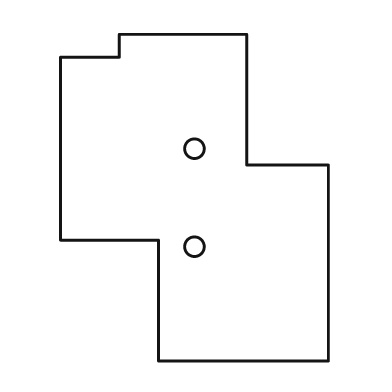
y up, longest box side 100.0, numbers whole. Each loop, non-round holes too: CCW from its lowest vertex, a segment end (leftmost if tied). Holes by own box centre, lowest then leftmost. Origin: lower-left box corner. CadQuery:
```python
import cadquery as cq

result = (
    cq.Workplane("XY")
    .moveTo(30.0, 0.0)
    .lineTo(82.0, 0.0)
    .lineTo(82.0, 60.0)
    .lineTo(57.0, 60.0)
    .lineTo(57.0, 100.0)
    .lineTo(18.0, 100.0)
    .lineTo(18.0, 93.0)
    .lineTo(0.0, 93.0)
    .lineTo(0.0, 37.0)
    .lineTo(30.0, 37.0)
    .close()
    .moveTo(41.0, 35.0)
    .circle(3.0)
    .moveTo(41.0, 65.0)
    .circle(3.0)
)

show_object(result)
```